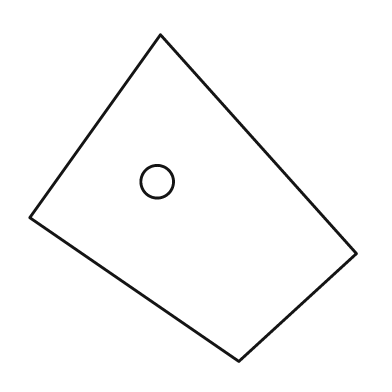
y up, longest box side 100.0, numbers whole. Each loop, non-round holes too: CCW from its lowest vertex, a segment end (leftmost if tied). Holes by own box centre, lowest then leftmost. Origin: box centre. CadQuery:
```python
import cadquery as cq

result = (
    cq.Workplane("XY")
    .moveTo(14.0, -50.0)
    .lineTo(50.0, -17.0)
    .lineTo(-10.0, 50.0)
    .lineTo(-50.0, -6.0)
    .close()
    .moveTo(-11.0, 5.0)
    .circle(5.0)
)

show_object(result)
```